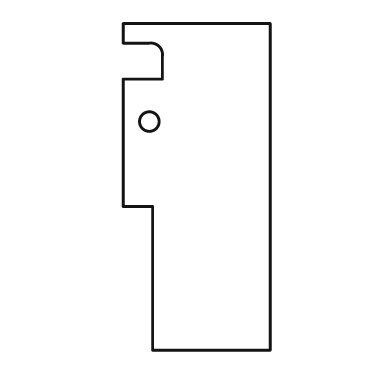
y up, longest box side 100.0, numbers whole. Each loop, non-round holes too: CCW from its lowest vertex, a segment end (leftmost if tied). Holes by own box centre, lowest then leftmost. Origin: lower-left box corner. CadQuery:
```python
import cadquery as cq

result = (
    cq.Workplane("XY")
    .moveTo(9.0, 0.0)
    .lineTo(45.0, 0.0)
    .lineTo(45.0, 100.0)
    .lineTo(0.0, 100.0)
    .lineTo(0.0, 94.0)
    .lineTo(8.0, 94.0)
    .threePointArc((11.0, 93.0), (12.0, 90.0))
    .lineTo(12.0, 83.0)
    .lineTo(0.0, 83.0)
    .lineTo(0.0, 44.0)
    .lineTo(9.0, 44.0)
    .close()
    .moveTo(8.0, 70.0)
    .circle(3.0)
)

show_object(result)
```